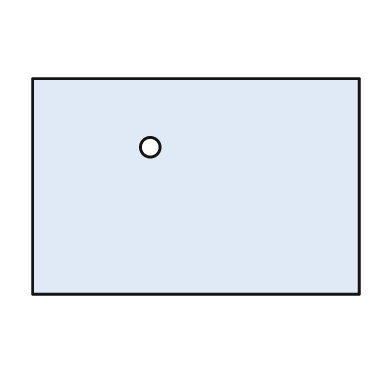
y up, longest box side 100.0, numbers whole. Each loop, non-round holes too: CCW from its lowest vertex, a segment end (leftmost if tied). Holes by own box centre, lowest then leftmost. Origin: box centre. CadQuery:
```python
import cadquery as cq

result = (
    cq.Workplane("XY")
    .moveTo(-50.0, -33.0)
    .lineTo(50.0, -33.0)
    .lineTo(50.0, 33.0)
    .lineTo(-50.0, 33.0)
    .close()
    .moveTo(-14.0, 12.0)
    .circle(3.0)
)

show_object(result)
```